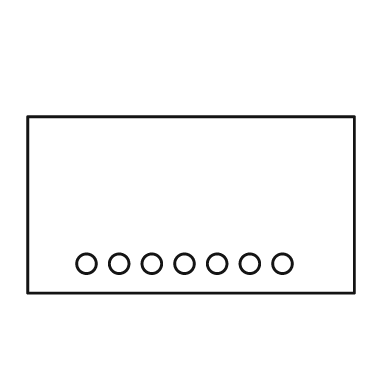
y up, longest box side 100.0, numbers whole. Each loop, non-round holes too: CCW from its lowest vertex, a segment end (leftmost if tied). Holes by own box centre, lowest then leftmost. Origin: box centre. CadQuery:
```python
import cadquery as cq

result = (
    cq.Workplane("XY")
    .moveTo(-50.0, -27.0)
    .lineTo(50.0, -27.0)
    .lineTo(50.0, 27.0)
    .lineTo(-50.0, 27.0)
    .close()
    .moveTo(-32.0, -18.0)
    .circle(3.0)
    .moveTo(-22.0, -18.0)
    .circle(3.0)
    .moveTo(-12.0, -18.0)
    .circle(3.0)
    .moveTo(-2.0, -18.0)
    .circle(3.0)
    .moveTo(8.0, -18.0)
    .circle(3.0)
    .moveTo(18.0, -18.0)
    .circle(3.0)
    .moveTo(28.0, -18.0)
    .circle(3.0)
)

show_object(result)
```